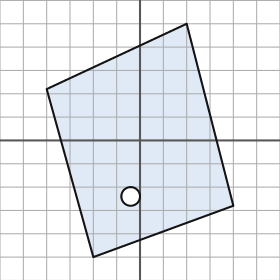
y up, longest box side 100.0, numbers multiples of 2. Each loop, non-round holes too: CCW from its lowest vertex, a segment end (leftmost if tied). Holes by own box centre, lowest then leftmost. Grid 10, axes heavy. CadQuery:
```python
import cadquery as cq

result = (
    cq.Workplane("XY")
    .moveTo(-20.0, -50.0)
    .lineTo(40.0, -28.0)
    .lineTo(20.0, 50.0)
    .lineTo(-40.0, 22.0)
    .close()
    .moveTo(-4.0, -24.0)
    .circle(4.0)
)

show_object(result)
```